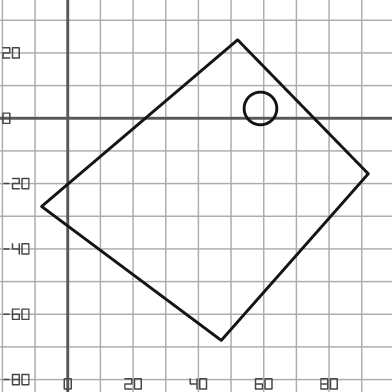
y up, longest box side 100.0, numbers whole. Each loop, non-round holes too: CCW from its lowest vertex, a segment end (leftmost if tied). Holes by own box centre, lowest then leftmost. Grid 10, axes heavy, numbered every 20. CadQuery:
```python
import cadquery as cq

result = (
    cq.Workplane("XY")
    .moveTo(47.0, -68.0)
    .lineTo(92.0, -17.0)
    .lineTo(52.0, 24.0)
    .lineTo(-8.0, -27.0)
    .close()
    .moveTo(59.0, 3.0)
    .circle(5.0)
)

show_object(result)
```